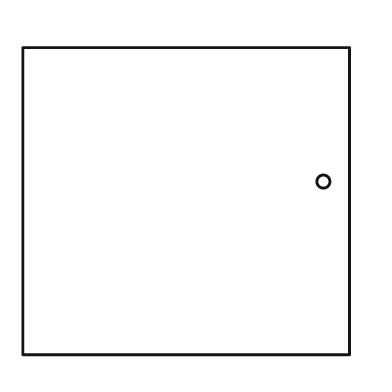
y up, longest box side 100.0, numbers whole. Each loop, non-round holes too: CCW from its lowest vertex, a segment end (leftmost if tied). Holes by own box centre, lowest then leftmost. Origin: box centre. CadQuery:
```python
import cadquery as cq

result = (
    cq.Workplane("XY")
    .moveTo(-50.0, -47.0)
    .lineTo(50.0, -47.0)
    .lineTo(50.0, 47.0)
    .lineTo(-50.0, 47.0)
    .close()
    .moveTo(42.0, 6.0)
    .circle(2.0)
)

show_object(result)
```